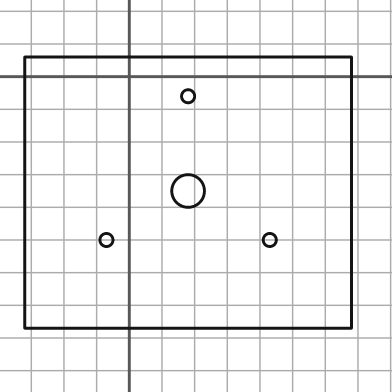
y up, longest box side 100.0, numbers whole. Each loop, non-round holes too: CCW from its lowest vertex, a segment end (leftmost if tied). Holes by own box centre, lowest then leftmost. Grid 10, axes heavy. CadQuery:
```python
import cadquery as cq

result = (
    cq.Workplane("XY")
    .moveTo(-32.0, -77.0)
    .lineTo(68.0, -77.0)
    .lineTo(68.0, 6.0)
    .lineTo(-32.0, 6.0)
    .close()
    .moveTo(-7.0, -50.0)
    .circle(2.0)
    .moveTo(43.0, -50.0)
    .circle(2.0)
    .moveTo(18.0, -35.0)
    .circle(5.0)
    .moveTo(18.0, -6.0)
    .circle(2.0)
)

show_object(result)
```